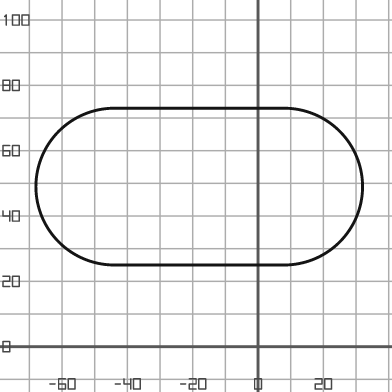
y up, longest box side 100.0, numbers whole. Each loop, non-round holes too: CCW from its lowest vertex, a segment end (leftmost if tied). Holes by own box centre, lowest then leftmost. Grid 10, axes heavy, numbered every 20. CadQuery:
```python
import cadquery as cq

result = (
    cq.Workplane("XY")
    .moveTo(-44.0, 25.0)
    .lineTo(8.0, 25.0)
    .threePointArc((32.0, 49.0), (8.0, 73.0))
    .lineTo(-44.0, 73.0)
    .threePointArc((-68.0, 49.0), (-44.0, 25.0))
    .close()
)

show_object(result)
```